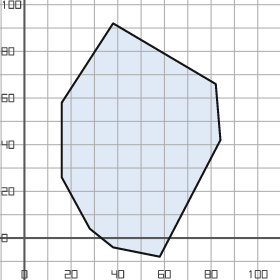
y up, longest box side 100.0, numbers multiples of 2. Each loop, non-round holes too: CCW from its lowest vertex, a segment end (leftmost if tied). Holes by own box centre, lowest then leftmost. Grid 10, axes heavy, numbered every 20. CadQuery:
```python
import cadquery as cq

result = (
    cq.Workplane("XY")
    .moveTo(58.0, -8.0)
    .lineTo(84.0, 42.0)
    .lineTo(82.0, 66.0)
    .lineTo(38.0, 92.0)
    .lineTo(16.0, 58.0)
    .lineTo(16.0, 26.0)
    .lineTo(28.0, 4.0)
    .lineTo(38.0, -4.0)
    .close()
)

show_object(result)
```